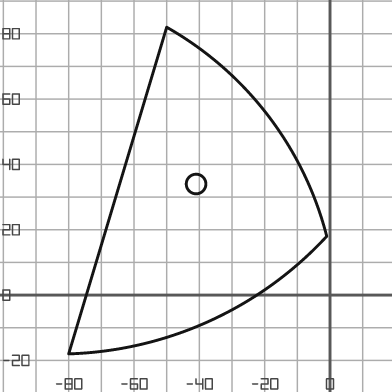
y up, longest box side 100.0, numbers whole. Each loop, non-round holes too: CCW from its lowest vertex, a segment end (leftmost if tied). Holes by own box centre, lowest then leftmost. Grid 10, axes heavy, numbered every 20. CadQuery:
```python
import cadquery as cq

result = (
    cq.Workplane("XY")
    .moveTo(-80.0, -18.0)
    .threePointArc((-37.0, -8.0), (-1.0, 18.0))
    .threePointArc((-19.0, 55.0), (-50.0, 82.0))
    .close()
    .moveTo(-41.0, 34.0)
    .circle(3.0)
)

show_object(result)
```